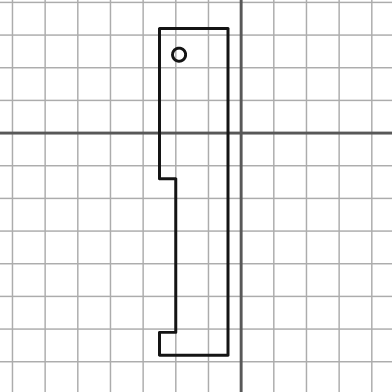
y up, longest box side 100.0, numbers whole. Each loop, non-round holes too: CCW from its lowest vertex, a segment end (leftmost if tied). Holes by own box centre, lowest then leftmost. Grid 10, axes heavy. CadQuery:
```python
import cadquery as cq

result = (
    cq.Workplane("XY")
    .moveTo(-25.0, -68.0)
    .lineTo(-4.0, -68.0)
    .lineTo(-4.0, 32.0)
    .lineTo(-25.0, 32.0)
    .lineTo(-25.0, -14.0)
    .lineTo(-20.0, -14.0)
    .lineTo(-20.0, -61.0)
    .lineTo(-25.0, -61.0)
    .close()
    .moveTo(-19.0, 24.0)
    .circle(2.0)
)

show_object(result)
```